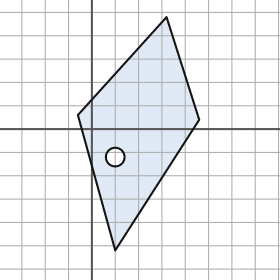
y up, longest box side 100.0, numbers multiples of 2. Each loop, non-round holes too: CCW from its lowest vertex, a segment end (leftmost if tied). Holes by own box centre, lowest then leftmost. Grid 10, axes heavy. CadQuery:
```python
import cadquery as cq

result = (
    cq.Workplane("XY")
    .moveTo(10.0, -52.0)
    .lineTo(46.0, 4.0)
    .lineTo(32.0, 48.0)
    .lineTo(-6.0, 6.0)
    .close()
    .moveTo(10.0, -12.0)
    .circle(4.0)
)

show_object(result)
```